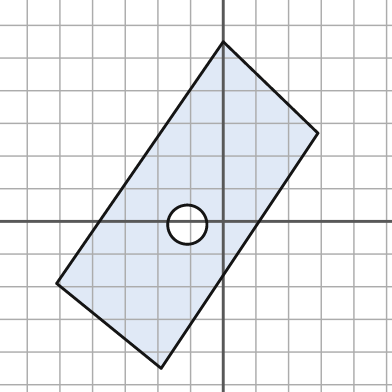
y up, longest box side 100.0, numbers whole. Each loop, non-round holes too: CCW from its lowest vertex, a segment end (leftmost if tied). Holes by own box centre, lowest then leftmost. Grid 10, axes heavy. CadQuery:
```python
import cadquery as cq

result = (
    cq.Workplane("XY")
    .moveTo(-19.0, -45.0)
    .lineTo(29.0, 27.0)
    .lineTo(0.0, 55.0)
    .lineTo(-51.0, -19.0)
    .close()
    .moveTo(-11.0, -1.0)
    .circle(6.0)
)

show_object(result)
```